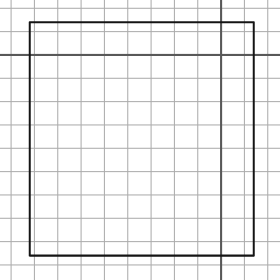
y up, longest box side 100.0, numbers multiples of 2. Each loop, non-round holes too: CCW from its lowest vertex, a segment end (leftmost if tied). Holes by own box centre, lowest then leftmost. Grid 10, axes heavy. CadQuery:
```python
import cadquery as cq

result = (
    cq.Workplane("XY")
    .moveTo(-82.0, -86.0)
    .lineTo(14.0, -86.0)
    .lineTo(14.0, 14.0)
    .lineTo(-82.0, 14.0)
    .close()
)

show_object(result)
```